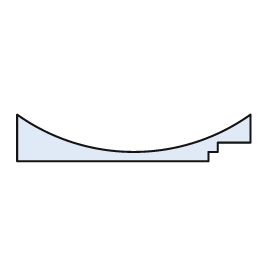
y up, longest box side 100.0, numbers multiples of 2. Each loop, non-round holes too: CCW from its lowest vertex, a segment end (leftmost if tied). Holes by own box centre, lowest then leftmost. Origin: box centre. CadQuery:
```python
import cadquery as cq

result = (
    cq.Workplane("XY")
    .moveTo(-50.0, -10.0)
    .lineTo(32.0, -10.0)
    .lineTo(32.0, -6.0)
    .lineTo(36.0, -6.0)
    .lineTo(36.0, -2.0)
    .lineTo(50.0, -2.0)
    .lineTo(50.0, 10.0)
    .threePointArc((0.0, -6.0), (-50.0, 10.0))
    .close()
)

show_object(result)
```